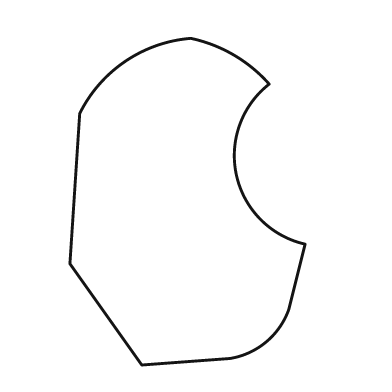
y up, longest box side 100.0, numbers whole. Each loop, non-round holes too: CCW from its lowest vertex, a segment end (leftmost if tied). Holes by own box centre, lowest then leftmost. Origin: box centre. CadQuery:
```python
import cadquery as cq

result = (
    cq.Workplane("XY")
    .moveTo(-14.0, -50.0)
    .lineTo(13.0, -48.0)
    .threePointArc((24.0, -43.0), (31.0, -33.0))
    .lineTo(36.0, -13.0)
    .threePointArc((15.0, 8.0), (25.0, 36.0))
    .threePointArc((14.0, 45.0), (1.0, 50.0))
    .threePointArc((-19.0, 43.0), (-33.0, 27.0))
    .lineTo(-36.0, -19.0)
    .close()
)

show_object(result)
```